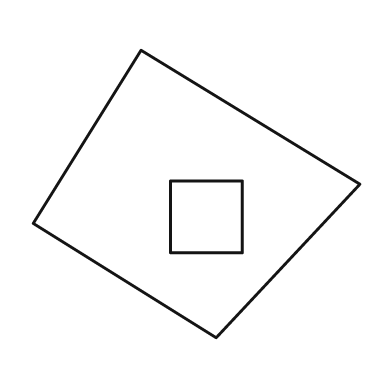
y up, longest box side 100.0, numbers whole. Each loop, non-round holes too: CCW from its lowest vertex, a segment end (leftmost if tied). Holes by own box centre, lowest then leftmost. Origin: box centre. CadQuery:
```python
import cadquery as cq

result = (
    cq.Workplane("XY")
    .moveTo(6.0, -44.0)
    .lineTo(50.0, 3.0)
    .lineTo(-17.0, 44.0)
    .lineTo(-50.0, -9.0)
    .close()
    .moveTo(-8.0, -18.0)
    .lineTo(14.0, -18.0)
    .lineTo(14.0, 4.0)
    .lineTo(-8.0, 4.0)
    .close()
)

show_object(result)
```